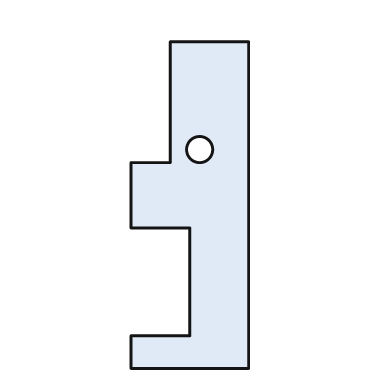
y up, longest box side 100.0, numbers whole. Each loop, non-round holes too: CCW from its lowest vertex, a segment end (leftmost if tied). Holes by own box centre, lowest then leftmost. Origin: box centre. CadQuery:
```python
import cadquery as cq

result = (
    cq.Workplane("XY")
    .moveTo(-18.0, -50.0)
    .lineTo(18.0, -50.0)
    .lineTo(18.0, 50.0)
    .lineTo(-6.0, 50.0)
    .lineTo(-6.0, 13.0)
    .lineTo(-18.0, 13.0)
    .lineTo(-18.0, -7.0)
    .lineTo(0.0, -7.0)
    .lineTo(0.0, -40.0)
    .lineTo(-18.0, -40.0)
    .close()
    .moveTo(3.0, 17.0)
    .circle(4.0)
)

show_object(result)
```